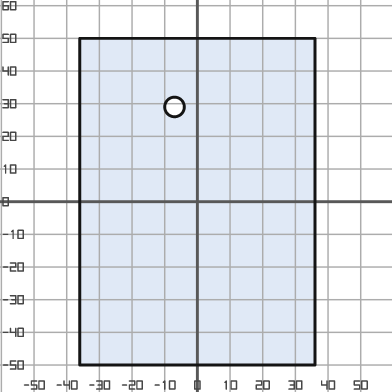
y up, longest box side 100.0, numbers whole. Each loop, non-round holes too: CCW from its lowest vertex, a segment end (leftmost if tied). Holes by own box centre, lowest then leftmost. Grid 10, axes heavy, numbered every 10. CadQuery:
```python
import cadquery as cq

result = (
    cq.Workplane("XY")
    .moveTo(-36.0, -50.0)
    .lineTo(36.0, -50.0)
    .lineTo(36.0, 50.0)
    .lineTo(-36.0, 50.0)
    .close()
    .moveTo(-7.0, 29.0)
    .circle(3.0)
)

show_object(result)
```